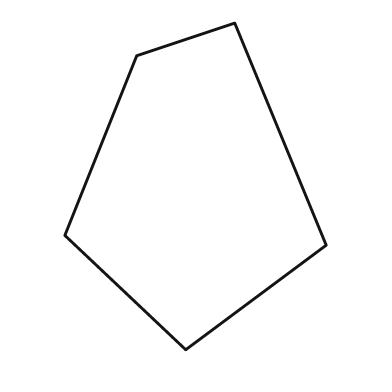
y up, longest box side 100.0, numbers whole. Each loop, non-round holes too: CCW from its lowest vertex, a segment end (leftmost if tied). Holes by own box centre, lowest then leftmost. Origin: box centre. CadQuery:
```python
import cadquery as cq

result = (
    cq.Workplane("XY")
    .moveTo(-3.0, -50.0)
    .lineTo(40.0, -18.0)
    .lineTo(12.0, 50.0)
    .lineTo(-18.0, 40.0)
    .lineTo(-40.0, -15.0)
    .close()
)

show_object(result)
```